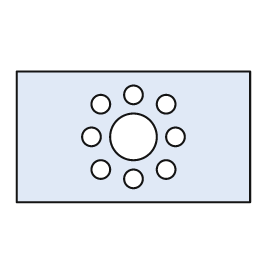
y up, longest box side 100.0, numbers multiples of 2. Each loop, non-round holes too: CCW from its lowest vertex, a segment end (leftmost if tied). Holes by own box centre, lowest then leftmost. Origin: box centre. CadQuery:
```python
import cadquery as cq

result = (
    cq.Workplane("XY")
    .moveTo(-50.0, -28.0)
    .lineTo(50.0, -28.0)
    .lineTo(50.0, 28.0)
    .lineTo(-50.0, 28.0)
    .close()
    .moveTo(0.0, -18.0)
    .circle(4.0)
    .moveTo(-14.0, -14.0)
    .circle(4.0)
    .moveTo(14.0, -14.0)
    .circle(4.0)
    .moveTo(-18.0, 0.0)
    .circle(4.0)
    .moveTo(0.0, 0.0)
    .circle(10.0)
    .moveTo(18.0, 0.0)
    .circle(4.0)
    .moveTo(-14.0, 14.0)
    .circle(4.0)
    .moveTo(14.0, 14.0)
    .circle(4.0)
    .moveTo(0.0, 18.0)
    .circle(4.0)
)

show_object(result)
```